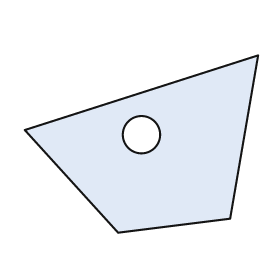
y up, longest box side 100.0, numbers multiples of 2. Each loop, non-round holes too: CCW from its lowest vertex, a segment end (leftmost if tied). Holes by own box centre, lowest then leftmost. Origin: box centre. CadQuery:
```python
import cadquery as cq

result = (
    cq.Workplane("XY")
    .moveTo(-10.0, -38.0)
    .lineTo(38.0, -32.0)
    .lineTo(50.0, 38.0)
    .lineTo(-50.0, 6.0)
    .close()
    .moveTo(0.0, 4.0)
    .circle(8.0)
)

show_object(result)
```